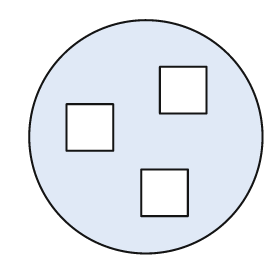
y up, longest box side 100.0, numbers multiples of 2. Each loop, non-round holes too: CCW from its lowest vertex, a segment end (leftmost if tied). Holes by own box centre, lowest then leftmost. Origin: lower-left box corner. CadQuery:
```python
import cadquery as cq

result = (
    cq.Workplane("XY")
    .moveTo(50.0, 50.0)
    .circle(50.0)
    .moveTo(48.0, 16.0)
    .lineTo(68.0, 16.0)
    .lineTo(68.0, 36.0)
    .lineTo(48.0, 36.0)
    .close()
    .moveTo(16.0, 44.0)
    .lineTo(36.0, 44.0)
    .lineTo(36.0, 64.0)
    .lineTo(16.0, 64.0)
    .close()
    .moveTo(56.0, 60.0)
    .lineTo(76.0, 60.0)
    .lineTo(76.0, 80.0)
    .lineTo(56.0, 80.0)
    .close()
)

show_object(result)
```